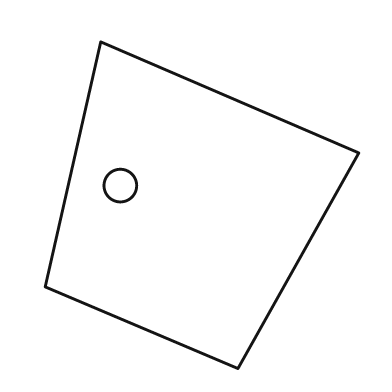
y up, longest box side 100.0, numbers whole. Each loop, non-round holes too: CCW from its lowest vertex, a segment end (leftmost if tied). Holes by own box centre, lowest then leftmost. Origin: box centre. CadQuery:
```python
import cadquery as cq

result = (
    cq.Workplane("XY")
    .moveTo(11.0, -50.0)
    .lineTo(48.0, 16.0)
    .lineTo(-31.0, 50.0)
    .lineTo(-48.0, -25.0)
    .close()
    .moveTo(-25.0, 6.0)
    .circle(5.0)
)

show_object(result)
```